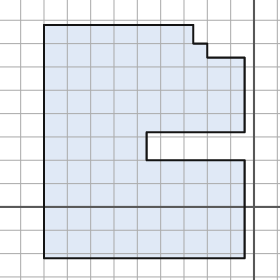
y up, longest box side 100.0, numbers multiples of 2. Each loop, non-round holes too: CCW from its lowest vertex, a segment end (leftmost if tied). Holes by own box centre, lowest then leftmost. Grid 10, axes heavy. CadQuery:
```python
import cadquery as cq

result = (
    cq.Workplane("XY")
    .moveTo(-90.0, -22.0)
    .lineTo(-4.0, -22.0)
    .lineTo(-4.0, 20.0)
    .lineTo(-46.0, 20.0)
    .lineTo(-46.0, 32.0)
    .lineTo(-4.0, 32.0)
    .lineTo(-4.0, 64.0)
    .lineTo(-20.0, 64.0)
    .lineTo(-20.0, 70.0)
    .lineTo(-26.0, 70.0)
    .lineTo(-26.0, 78.0)
    .lineTo(-90.0, 78.0)
    .close()
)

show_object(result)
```